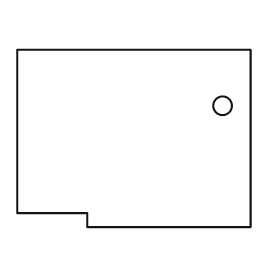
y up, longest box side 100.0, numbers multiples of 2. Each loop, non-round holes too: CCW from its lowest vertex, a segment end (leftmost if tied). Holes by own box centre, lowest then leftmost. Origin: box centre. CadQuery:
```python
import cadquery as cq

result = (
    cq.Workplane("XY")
    .moveTo(-20.0, -38.0)
    .lineTo(50.0, -38.0)
    .lineTo(50.0, 38.0)
    .lineTo(-50.0, 38.0)
    .lineTo(-50.0, -32.0)
    .lineTo(-20.0, -32.0)
    .close()
    .moveTo(38.0, 14.0)
    .circle(4.0)
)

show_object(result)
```